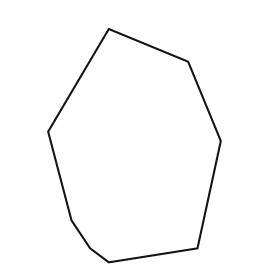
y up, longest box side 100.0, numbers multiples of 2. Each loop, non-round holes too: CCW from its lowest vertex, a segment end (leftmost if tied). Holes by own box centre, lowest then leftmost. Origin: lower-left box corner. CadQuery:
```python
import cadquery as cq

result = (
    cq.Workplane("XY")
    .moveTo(26.0, 0.0)
    .lineTo(64.0, 6.0)
    .lineTo(74.0, 52.0)
    .lineTo(60.0, 86.0)
    .lineTo(26.0, 100.0)
    .lineTo(0.0, 56.0)
    .lineTo(10.0, 18.0)
    .lineTo(18.0, 6.0)
    .close()
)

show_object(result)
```